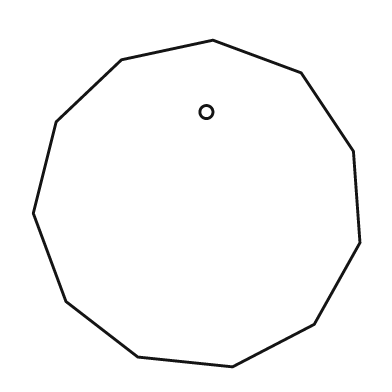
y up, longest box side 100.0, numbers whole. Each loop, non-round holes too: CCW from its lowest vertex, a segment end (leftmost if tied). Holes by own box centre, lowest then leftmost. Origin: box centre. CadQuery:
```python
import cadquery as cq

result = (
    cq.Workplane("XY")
    .moveTo(11.0, -50.0)
    .lineTo(36.0, -37.0)
    .lineTo(50.0, -12.0)
    .lineTo(48.0, 16.0)
    .lineTo(32.0, 40.0)
    .lineTo(5.0, 50.0)
    .lineTo(-23.0, 44.0)
    .lineTo(-43.0, 25.0)
    .lineTo(-50.0, -3.0)
    .lineTo(-40.0, -30.0)
    .lineTo(-18.0, -47.0)
    .close()
    .moveTo(3.0, 28.0)
    .circle(2.0)
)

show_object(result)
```